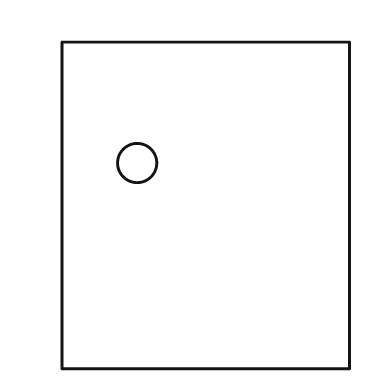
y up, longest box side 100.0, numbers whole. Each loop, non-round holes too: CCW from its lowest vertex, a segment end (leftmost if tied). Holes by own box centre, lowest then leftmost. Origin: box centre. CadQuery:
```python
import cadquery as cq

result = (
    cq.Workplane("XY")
    .moveTo(-44.0, -50.0)
    .lineTo(44.0, -50.0)
    .lineTo(44.0, 50.0)
    .lineTo(-44.0, 50.0)
    .close()
    .moveTo(-21.0, 13.0)
    .circle(6.0)
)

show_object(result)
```